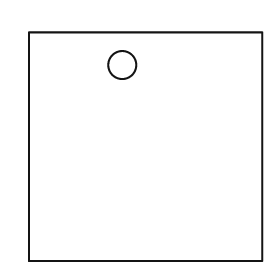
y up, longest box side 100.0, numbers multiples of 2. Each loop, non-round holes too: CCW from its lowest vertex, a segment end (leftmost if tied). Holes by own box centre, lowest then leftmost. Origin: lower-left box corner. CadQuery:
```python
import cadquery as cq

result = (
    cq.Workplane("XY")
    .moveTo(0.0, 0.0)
    .lineTo(100.0, 0.0)
    .lineTo(100.0, 98.0)
    .lineTo(0.0, 98.0)
    .close()
    .moveTo(40.0, 84.0)
    .circle(6.0)
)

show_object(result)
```